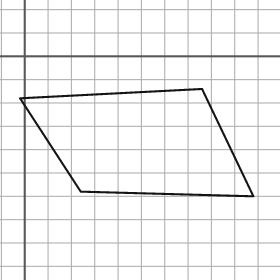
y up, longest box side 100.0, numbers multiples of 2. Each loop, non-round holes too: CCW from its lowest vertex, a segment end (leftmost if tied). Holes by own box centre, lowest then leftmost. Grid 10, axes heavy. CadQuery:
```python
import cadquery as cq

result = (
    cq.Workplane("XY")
    .moveTo(98.0, -60.0)
    .lineTo(76.0, -14.0)
    .lineTo(-2.0, -18.0)
    .lineTo(24.0, -58.0)
    .close()
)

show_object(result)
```